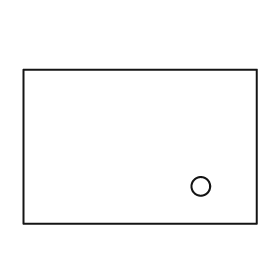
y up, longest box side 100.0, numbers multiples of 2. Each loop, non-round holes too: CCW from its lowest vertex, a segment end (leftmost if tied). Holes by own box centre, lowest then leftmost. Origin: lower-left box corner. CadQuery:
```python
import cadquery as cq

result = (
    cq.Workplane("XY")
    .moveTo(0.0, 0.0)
    .lineTo(100.0, 0.0)
    .lineTo(100.0, 66.0)
    .lineTo(0.0, 66.0)
    .close()
    .moveTo(76.0, 16.0)
    .circle(4.0)
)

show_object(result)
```